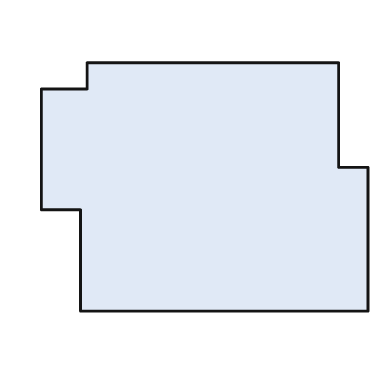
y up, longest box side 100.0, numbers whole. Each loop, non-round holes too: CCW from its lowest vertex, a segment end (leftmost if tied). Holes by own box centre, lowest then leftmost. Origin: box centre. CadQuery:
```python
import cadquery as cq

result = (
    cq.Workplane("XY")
    .moveTo(-38.0, -38.0)
    .lineTo(50.0, -38.0)
    .lineTo(50.0, 6.0)
    .lineTo(41.0, 6.0)
    .lineTo(41.0, 38.0)
    .lineTo(-36.0, 38.0)
    .lineTo(-36.0, 30.0)
    .lineTo(-50.0, 30.0)
    .lineTo(-50.0, -7.0)
    .lineTo(-38.0, -7.0)
    .close()
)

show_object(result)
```